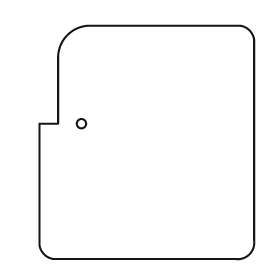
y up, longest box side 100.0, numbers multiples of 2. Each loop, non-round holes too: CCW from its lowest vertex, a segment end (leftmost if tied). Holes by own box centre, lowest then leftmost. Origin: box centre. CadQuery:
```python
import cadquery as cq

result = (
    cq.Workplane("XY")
    .moveTo(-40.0, -50.0)
    .lineTo(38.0, -50.0)
    .threePointArc((44.0, -48.0), (46.0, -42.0))
    .lineTo(46.0, 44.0)
    .threePointArc((44.0, 48.0), (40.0, 50.0))
    .lineTo(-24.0, 50.0)
    .threePointArc((-34.0, 46.0), (-38.0, 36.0))
    .lineTo(-38.0, 8.0)
    .lineTo(-46.0, 8.0)
    .lineTo(-46.0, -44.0)
    .threePointArc((-44.0, -48.0), (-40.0, -50.0))
    .close()
    .moveTo(-28.0, 8.0)
    .circle(2.0)
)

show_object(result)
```